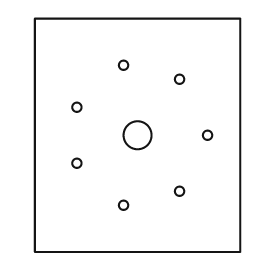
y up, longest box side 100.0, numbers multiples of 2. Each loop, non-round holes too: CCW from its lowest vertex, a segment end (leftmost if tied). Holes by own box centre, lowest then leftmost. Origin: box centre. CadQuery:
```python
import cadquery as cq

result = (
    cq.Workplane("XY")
    .moveTo(-44.0, -50.0)
    .lineTo(44.0, -50.0)
    .lineTo(44.0, 50.0)
    .lineTo(-44.0, 50.0)
    .close()
    .moveTo(-6.0, -30.0)
    .circle(2.0)
    .moveTo(18.0, -24.0)
    .circle(2.0)
    .moveTo(-26.0, -12.0)
    .circle(2.0)
    .moveTo(0.0, 0.0)
    .circle(6.0)
    .moveTo(30.0, 0.0)
    .circle(2.0)
    .moveTo(-26.0, 12.0)
    .circle(2.0)
    .moveTo(18.0, 24.0)
    .circle(2.0)
    .moveTo(-6.0, 30.0)
    .circle(2.0)
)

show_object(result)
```